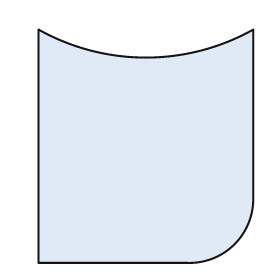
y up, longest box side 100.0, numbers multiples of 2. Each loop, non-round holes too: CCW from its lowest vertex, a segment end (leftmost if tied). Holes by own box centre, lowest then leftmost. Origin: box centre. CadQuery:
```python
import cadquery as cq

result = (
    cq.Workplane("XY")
    .moveTo(-46.0, -50.0)
    .lineTo(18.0, -50.0)
    .threePointArc((38.0, -42.0), (46.0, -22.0))
    .lineTo(46.0, 50.0)
    .threePointArc((0.0, 38.0), (-46.0, 50.0))
    .close()
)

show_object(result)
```